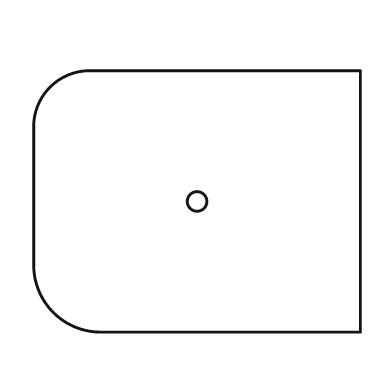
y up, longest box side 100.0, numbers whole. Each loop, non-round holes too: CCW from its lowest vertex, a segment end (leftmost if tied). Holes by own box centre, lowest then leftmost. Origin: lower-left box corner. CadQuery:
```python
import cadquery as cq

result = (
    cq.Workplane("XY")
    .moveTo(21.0, 0.0)
    .lineTo(100.0, 0.0)
    .lineTo(100.0, 80.0)
    .lineTo(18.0, 80.0)
    .threePointArc((5.0, 75.0), (0.0, 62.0))
    .lineTo(0.0, 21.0)
    .threePointArc((6.0, 6.0), (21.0, 0.0))
    .close()
    .moveTo(50.0, 40.0)
    .circle(3.0)
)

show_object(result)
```